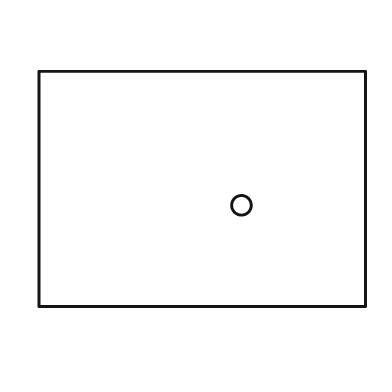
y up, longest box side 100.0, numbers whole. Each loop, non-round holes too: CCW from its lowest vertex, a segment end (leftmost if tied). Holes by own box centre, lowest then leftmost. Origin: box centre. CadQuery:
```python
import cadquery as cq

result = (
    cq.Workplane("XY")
    .moveTo(-50.0, -36.0)
    .lineTo(50.0, -36.0)
    .lineTo(50.0, 36.0)
    .lineTo(-50.0, 36.0)
    .close()
    .moveTo(12.0, -5.0)
    .circle(3.0)
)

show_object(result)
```